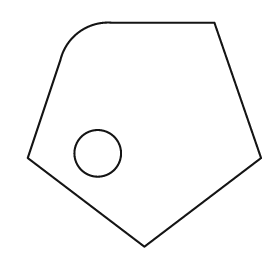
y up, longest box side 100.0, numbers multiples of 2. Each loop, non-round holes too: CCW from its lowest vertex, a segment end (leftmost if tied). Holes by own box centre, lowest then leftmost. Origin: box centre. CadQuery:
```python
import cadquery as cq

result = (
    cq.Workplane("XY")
    .moveTo(0.0, -48.0)
    .lineTo(50.0, -10.0)
    .lineTo(30.0, 48.0)
    .lineTo(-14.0, 48.0)
    .threePointArc((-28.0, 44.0), (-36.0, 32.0))
    .lineTo(-50.0, -10.0)
    .close()
    .moveTo(-20.0, -8.0)
    .circle(10.0)
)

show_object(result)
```